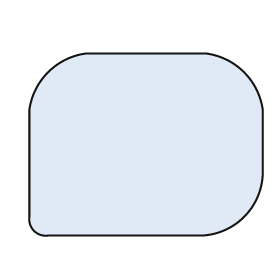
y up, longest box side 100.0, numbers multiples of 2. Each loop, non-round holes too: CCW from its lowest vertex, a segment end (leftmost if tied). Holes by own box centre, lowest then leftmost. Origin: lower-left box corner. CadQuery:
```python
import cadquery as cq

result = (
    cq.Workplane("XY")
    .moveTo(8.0, 0.0)
    .lineTo(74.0, 0.0)
    .threePointArc((92.0, 8.0), (100.0, 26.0))
    .lineTo(100.0, 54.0)
    .threePointArc((92.0, 70.0), (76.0, 78.0))
    .lineTo(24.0, 78.0)
    .threePointArc((8.0, 70.0), (0.0, 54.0))
    .lineTo(0.0, 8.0)
    .threePointArc((2.0, 2.0), (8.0, 0.0))
    .close()
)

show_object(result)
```